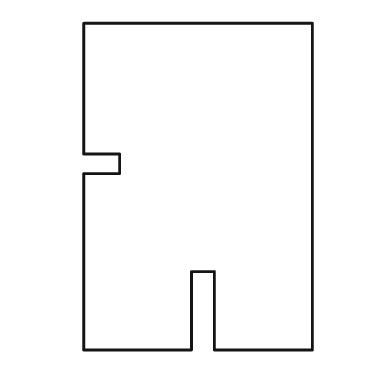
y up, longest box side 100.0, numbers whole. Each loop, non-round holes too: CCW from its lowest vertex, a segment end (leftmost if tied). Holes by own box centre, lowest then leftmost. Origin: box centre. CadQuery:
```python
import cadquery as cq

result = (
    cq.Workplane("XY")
    .moveTo(-35.0, -50.0)
    .lineTo(-2.0, -50.0)
    .lineTo(-2.0, -26.0)
    .lineTo(5.0, -26.0)
    .lineTo(5.0, -50.0)
    .lineTo(35.0, -50.0)
    .lineTo(35.0, 50.0)
    .lineTo(-35.0, 50.0)
    .lineTo(-35.0, 10.0)
    .lineTo(-24.0, 10.0)
    .lineTo(-24.0, 4.0)
    .lineTo(-35.0, 4.0)
    .close()
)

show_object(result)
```